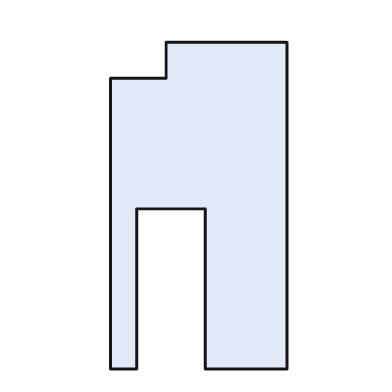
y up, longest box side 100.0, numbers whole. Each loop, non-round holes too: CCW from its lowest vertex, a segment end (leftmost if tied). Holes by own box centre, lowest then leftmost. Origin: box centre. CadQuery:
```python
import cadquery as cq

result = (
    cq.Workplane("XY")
    .moveTo(-27.0, -50.0)
    .lineTo(-19.0, -50.0)
    .lineTo(-19.0, -1.0)
    .lineTo(2.0, -1.0)
    .lineTo(2.0, -50.0)
    .lineTo(27.0, -50.0)
    .lineTo(27.0, 50.0)
    .lineTo(-10.0, 50.0)
    .lineTo(-10.0, 39.0)
    .lineTo(-27.0, 39.0)
    .close()
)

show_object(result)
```